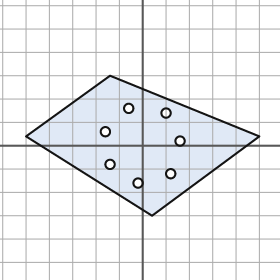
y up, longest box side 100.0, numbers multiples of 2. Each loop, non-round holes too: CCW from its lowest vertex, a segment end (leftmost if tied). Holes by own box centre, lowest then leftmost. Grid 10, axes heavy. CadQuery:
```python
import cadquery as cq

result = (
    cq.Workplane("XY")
    .moveTo(4.0, -30.0)
    .lineTo(50.0, 4.0)
    .lineTo(-14.0, 30.0)
    .lineTo(-50.0, 4.0)
    .close()
    .moveTo(-2.0, -16.0)
    .circle(2.0)
    .moveTo(12.0, -12.0)
    .circle(2.0)
    .moveTo(-14.0, -8.0)
    .circle(2.0)
    .moveTo(16.0, 2.0)
    .circle(2.0)
    .moveTo(-16.0, 6.0)
    .circle(2.0)
    .moveTo(10.0, 14.0)
    .circle(2.0)
    .moveTo(-6.0, 16.0)
    .circle(2.0)
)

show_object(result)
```